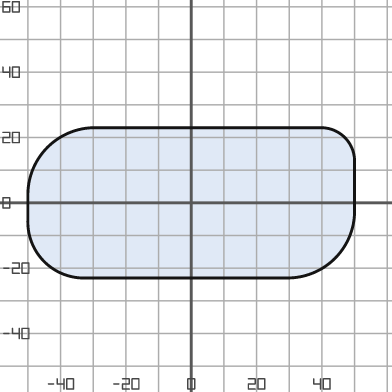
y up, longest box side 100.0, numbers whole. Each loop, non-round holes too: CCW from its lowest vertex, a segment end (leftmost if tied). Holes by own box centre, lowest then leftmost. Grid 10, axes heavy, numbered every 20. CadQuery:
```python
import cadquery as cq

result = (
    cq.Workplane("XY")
    .moveTo(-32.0, -23.0)
    .lineTo(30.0, -23.0)
    .threePointArc((44.0, -17.0), (50.0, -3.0))
    .lineTo(50.0, 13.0)
    .threePointArc((47.0, 20.0), (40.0, 23.0))
    .lineTo(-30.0, 23.0)
    .threePointArc((-44.0, 17.0), (-50.0, 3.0))
    .lineTo(-50.0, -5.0)
    .threePointArc((-45.0, -18.0), (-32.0, -23.0))
    .close()
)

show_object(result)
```